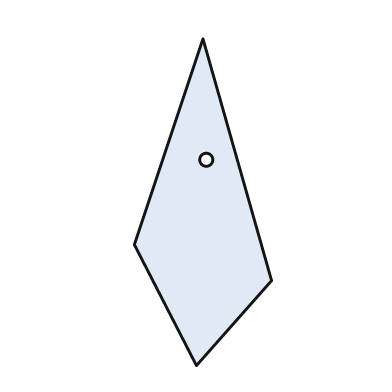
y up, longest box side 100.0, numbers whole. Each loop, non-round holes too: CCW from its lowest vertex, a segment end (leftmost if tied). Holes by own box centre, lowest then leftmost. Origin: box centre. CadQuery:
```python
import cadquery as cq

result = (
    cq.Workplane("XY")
    .moveTo(-2.0, -50.0)
    .lineTo(21.0, -24.0)
    .lineTo(0.0, 50.0)
    .lineTo(-21.0, -13.0)
    .close()
    .moveTo(1.0, 13.0)
    .circle(2.0)
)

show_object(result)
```